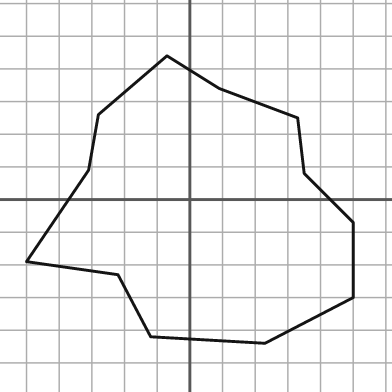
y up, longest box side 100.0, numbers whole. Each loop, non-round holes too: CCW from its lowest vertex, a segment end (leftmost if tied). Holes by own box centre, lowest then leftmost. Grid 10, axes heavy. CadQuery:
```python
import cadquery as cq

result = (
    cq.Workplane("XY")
    .moveTo(23.0, -44.0)
    .lineTo(50.0, -30.0)
    .lineTo(50.0, -7.0)
    .lineTo(35.0, 8.0)
    .lineTo(33.0, 25.0)
    .lineTo(9.0, 34.0)
    .lineTo(-7.0, 44.0)
    .lineTo(-28.0, 26.0)
    .lineTo(-31.0, 9.0)
    .lineTo(-50.0, -19.0)
    .lineTo(-22.0, -23.0)
    .lineTo(-12.0, -42.0)
    .close()
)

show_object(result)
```